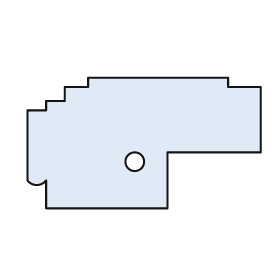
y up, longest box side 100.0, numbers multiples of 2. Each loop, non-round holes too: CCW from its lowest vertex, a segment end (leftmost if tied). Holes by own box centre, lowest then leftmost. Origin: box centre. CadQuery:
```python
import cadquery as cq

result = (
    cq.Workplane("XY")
    .moveTo(-42.0, -28.0)
    .lineTo(10.0, -28.0)
    .lineTo(10.0, -4.0)
    .lineTo(50.0, -4.0)
    .lineTo(50.0, 24.0)
    .lineTo(36.0, 24.0)
    .lineTo(36.0, 28.0)
    .lineTo(-24.0, 28.0)
    .lineTo(-24.0, 24.0)
    .lineTo(-34.0, 24.0)
    .lineTo(-34.0, 18.0)
    .lineTo(-42.0, 18.0)
    .lineTo(-42.0, 14.0)
    .lineTo(-50.0, 14.0)
    .lineTo(-50.0, -16.0)
    .threePointArc((-46.0, -18.0), (-42.0, -16.0))
    .close()
    .moveTo(-4.0, -8.0)
    .circle(4.0)
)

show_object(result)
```